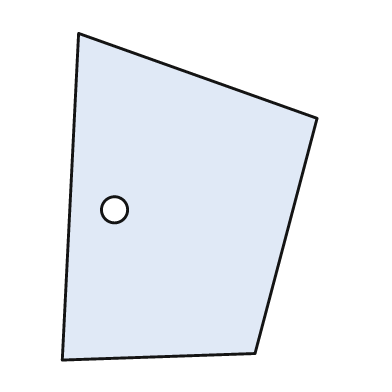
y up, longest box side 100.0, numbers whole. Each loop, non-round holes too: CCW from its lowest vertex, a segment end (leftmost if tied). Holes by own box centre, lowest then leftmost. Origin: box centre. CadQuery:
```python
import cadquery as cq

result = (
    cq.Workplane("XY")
    .moveTo(-39.0, -50.0)
    .lineTo(20.0, -48.0)
    .lineTo(39.0, 24.0)
    .lineTo(-34.0, 50.0)
    .close()
    .moveTo(-23.0, -4.0)
    .circle(4.0)
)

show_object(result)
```